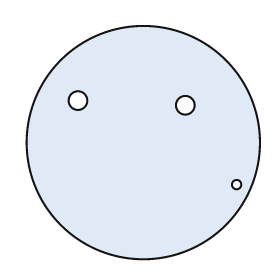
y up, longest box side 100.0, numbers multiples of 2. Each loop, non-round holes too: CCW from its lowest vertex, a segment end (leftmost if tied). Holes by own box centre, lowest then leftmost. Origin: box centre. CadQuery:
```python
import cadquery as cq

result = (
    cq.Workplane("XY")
    .moveTo(0.0, 0.0)
    .circle(50.0)
    .moveTo(40.0, -18.0)
    .circle(2.0)
    .moveTo(18.0, 16.0)
    .circle(4.0)
    .moveTo(-28.0, 18.0)
    .circle(4.0)
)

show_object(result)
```